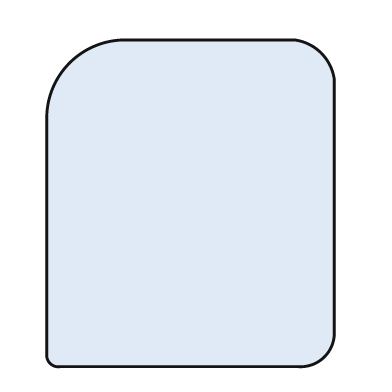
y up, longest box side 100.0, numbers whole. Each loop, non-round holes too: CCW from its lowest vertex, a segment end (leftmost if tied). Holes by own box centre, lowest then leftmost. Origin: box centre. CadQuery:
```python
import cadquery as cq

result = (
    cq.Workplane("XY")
    .moveTo(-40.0, -50.0)
    .lineTo(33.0, -50.0)
    .threePointArc((41.0, -47.0), (44.0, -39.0))
    .lineTo(44.0, 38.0)
    .threePointArc((40.0, 46.0), (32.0, 50.0))
    .lineTo(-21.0, 50.0)
    .threePointArc((-37.0, 43.0), (-44.0, 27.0))
    .lineTo(-44.0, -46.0)
    .threePointArc((-43.0, -49.0), (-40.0, -50.0))
    .close()
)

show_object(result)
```